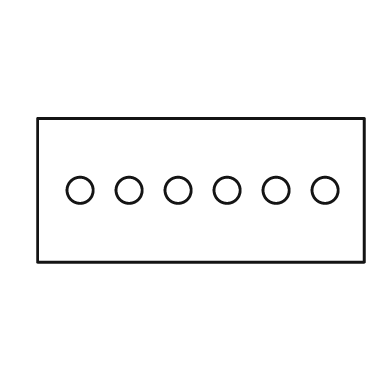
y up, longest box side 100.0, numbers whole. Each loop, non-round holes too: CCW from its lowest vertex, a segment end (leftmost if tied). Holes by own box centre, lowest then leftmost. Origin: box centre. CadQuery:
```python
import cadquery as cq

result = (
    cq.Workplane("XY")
    .moveTo(-50.0, -22.0)
    .lineTo(50.0, -22.0)
    .lineTo(50.0, 22.0)
    .lineTo(-50.0, 22.0)
    .close()
    .moveTo(-37.0, 0.0)
    .circle(4.0)
    .moveTo(-22.0, 0.0)
    .circle(4.0)
    .moveTo(-7.0, 0.0)
    .circle(4.0)
    .moveTo(8.0, 0.0)
    .circle(4.0)
    .moveTo(23.0, 0.0)
    .circle(4.0)
    .moveTo(38.0, 0.0)
    .circle(4.0)
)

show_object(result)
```